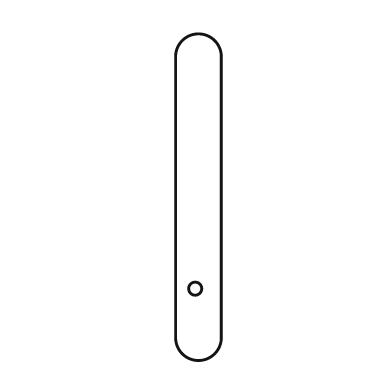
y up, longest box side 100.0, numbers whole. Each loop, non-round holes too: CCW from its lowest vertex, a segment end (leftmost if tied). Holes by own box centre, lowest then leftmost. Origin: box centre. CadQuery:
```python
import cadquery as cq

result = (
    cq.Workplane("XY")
    .moveTo(-7.0, -43.0)
    .threePointArc((0.0, -50.0), (7.0, -43.0))
    .lineTo(7.0, 43.0)
    .threePointArc((0.0, 50.0), (-7.0, 43.0))
    .close()
    .moveTo(-1.0, -28.0)
    .circle(2.0)
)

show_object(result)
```